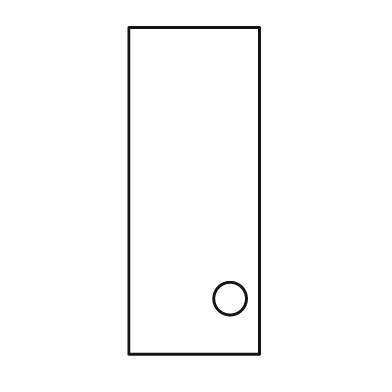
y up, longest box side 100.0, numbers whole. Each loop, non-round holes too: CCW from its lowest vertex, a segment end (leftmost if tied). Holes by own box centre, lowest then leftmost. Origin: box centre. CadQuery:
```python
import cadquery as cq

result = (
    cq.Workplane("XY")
    .moveTo(-20.0, -50.0)
    .lineTo(20.0, -50.0)
    .lineTo(20.0, 50.0)
    .lineTo(-20.0, 50.0)
    .close()
    .moveTo(11.0, -33.0)
    .circle(5.0)
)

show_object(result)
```